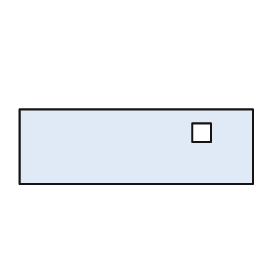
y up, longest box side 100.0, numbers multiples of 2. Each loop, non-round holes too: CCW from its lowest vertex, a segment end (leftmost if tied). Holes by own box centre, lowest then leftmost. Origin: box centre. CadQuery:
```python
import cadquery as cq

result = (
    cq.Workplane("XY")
    .moveTo(-50.0, -16.0)
    .lineTo(50.0, -16.0)
    .lineTo(50.0, 16.0)
    .lineTo(-50.0, 16.0)
    .close()
    .moveTo(24.0, 2.0)
    .lineTo(32.0, 2.0)
    .lineTo(32.0, 10.0)
    .lineTo(24.0, 10.0)
    .close()
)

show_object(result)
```